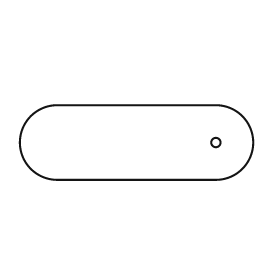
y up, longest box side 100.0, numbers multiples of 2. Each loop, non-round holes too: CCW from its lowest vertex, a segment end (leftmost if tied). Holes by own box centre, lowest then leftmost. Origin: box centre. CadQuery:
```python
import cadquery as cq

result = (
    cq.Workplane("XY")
    .moveTo(-34.0, -16.0)
    .lineTo(34.0, -16.0)
    .threePointArc((50.0, 0.0), (34.0, 16.0))
    .lineTo(-34.0, 16.0)
    .threePointArc((-50.0, 0.0), (-34.0, -16.0))
    .close()
    .moveTo(34.0, 0.0)
    .circle(2.0)
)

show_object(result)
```